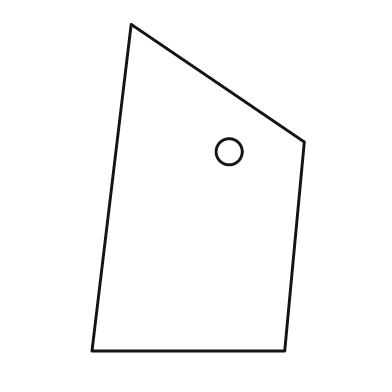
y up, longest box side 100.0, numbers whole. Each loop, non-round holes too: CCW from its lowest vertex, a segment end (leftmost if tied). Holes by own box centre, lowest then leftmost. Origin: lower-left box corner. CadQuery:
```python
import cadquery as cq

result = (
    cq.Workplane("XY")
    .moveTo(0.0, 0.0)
    .lineTo(59.0, 0.0)
    .lineTo(65.0, 64.0)
    .lineTo(12.0, 100.0)
    .close()
    .moveTo(42.0, 61.0)
    .circle(4.0)
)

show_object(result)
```